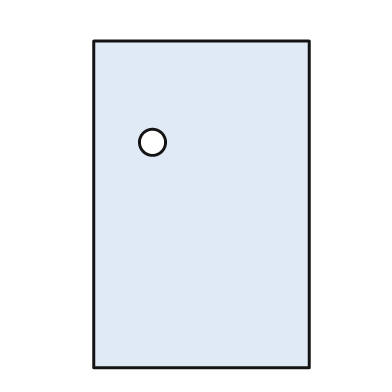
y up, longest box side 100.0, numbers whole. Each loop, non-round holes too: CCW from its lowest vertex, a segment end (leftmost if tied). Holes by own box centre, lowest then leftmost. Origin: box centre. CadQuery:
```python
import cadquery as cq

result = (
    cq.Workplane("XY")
    .moveTo(-33.0, -50.0)
    .lineTo(33.0, -50.0)
    .lineTo(33.0, 50.0)
    .lineTo(-33.0, 50.0)
    .close()
    .moveTo(-15.0, 19.0)
    .circle(4.0)
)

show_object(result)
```